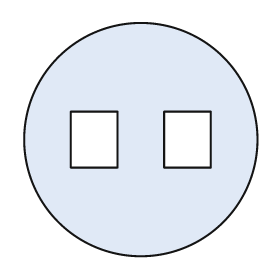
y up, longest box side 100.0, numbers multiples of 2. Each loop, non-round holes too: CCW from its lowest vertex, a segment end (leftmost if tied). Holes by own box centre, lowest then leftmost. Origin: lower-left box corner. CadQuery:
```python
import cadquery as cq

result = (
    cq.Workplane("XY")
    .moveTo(50.0, 50.0)
    .circle(50.0)
    .moveTo(20.0, 38.0)
    .lineTo(40.0, 38.0)
    .lineTo(40.0, 62.0)
    .lineTo(20.0, 62.0)
    .close()
    .moveTo(60.0, 38.0)
    .lineTo(80.0, 38.0)
    .lineTo(80.0, 62.0)
    .lineTo(60.0, 62.0)
    .close()
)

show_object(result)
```